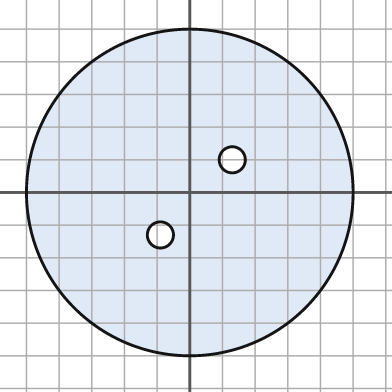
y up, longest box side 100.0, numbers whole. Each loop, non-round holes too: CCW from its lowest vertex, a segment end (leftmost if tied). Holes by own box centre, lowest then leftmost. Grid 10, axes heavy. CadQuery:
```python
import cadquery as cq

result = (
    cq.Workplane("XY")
    .moveTo(0.0, 0.0)
    .circle(50.0)
    .moveTo(-9.0, -13.0)
    .circle(4.0)
    .moveTo(13.0, 10.0)
    .circle(4.0)
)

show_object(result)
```